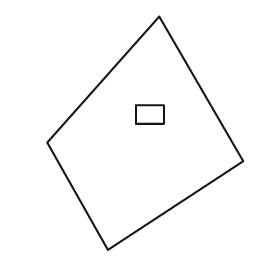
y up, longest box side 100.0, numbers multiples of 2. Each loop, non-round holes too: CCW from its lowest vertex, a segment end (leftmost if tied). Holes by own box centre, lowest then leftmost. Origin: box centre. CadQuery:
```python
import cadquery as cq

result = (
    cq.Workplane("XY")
    .moveTo(-16.0, -50.0)
    .lineTo(42.0, -12.0)
    .lineTo(6.0, 50.0)
    .lineTo(-42.0, -4.0)
    .close()
    .moveTo(-4.0, 4.0)
    .lineTo(8.0, 4.0)
    .lineTo(8.0, 12.0)
    .lineTo(-4.0, 12.0)
    .close()
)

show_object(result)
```